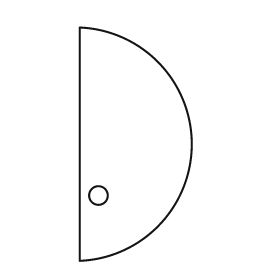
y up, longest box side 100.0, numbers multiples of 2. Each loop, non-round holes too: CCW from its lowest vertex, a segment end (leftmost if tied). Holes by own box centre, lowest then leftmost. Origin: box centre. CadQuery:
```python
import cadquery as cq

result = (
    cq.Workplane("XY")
    .moveTo(-24.0, -50.0)
    .threePointArc((24.0, 0.0), (-24.0, 50.0))
    .close()
    .moveTo(-16.0, -22.0)
    .circle(4.0)
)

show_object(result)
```